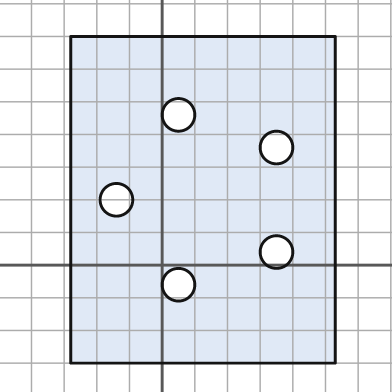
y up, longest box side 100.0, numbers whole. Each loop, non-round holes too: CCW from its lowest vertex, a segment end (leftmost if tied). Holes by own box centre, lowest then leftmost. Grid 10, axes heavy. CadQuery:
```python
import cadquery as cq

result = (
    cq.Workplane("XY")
    .moveTo(-28.0, -30.0)
    .lineTo(53.0, -30.0)
    .lineTo(53.0, 70.0)
    .lineTo(-28.0, 70.0)
    .close()
    .moveTo(5.0, -6.0)
    .circle(5.0)
    .moveTo(35.0, 4.0)
    .circle(5.0)
    .moveTo(-14.0, 20.0)
    .circle(5.0)
    .moveTo(35.0, 36.0)
    .circle(5.0)
    .moveTo(5.0, 46.0)
    .circle(5.0)
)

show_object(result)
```